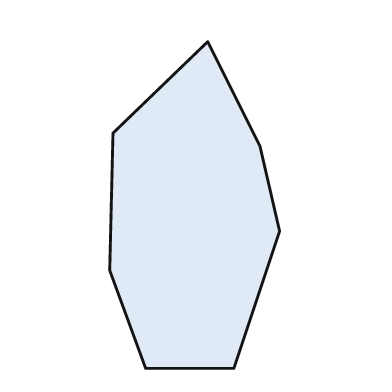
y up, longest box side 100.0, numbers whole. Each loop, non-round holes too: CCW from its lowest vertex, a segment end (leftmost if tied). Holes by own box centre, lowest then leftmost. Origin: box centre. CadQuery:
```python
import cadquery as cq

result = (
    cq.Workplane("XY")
    .moveTo(-15.0, -50.0)
    .lineTo(12.0, -50.0)
    .lineTo(26.0, -8.0)
    .lineTo(20.0, 18.0)
    .lineTo(4.0, 50.0)
    .lineTo(-25.0, 22.0)
    .lineTo(-26.0, -20.0)
    .close()
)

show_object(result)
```